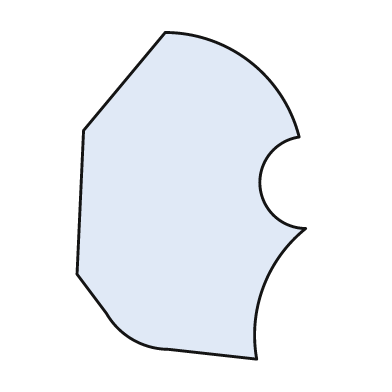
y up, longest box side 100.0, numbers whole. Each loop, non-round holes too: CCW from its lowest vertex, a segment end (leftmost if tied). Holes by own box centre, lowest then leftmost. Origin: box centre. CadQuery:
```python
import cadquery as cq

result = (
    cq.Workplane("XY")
    .moveTo(20.0, -50.0)
    .threePointArc((22.0, -28.0), (35.0, -10.0))
    .threePointArc((21.0, 3.0), (33.0, 18.0))
    .threePointArc((18.0, 41.0), (-8.0, 50.0))
    .lineTo(-33.0, 20.0)
    .lineTo(-35.0, -24.0)
    .lineTo(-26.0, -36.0)
    .threePointArc((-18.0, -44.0), (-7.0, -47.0))
    .close()
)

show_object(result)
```